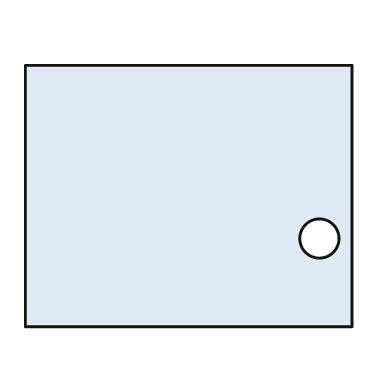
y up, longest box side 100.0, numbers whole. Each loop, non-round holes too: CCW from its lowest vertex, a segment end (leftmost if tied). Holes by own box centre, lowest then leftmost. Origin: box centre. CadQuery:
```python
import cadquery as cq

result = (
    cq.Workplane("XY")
    .moveTo(-50.0, -40.0)
    .lineTo(50.0, -40.0)
    .lineTo(50.0, 40.0)
    .lineTo(-50.0, 40.0)
    .close()
    .moveTo(40.0, -13.0)
    .circle(6.0)
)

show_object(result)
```